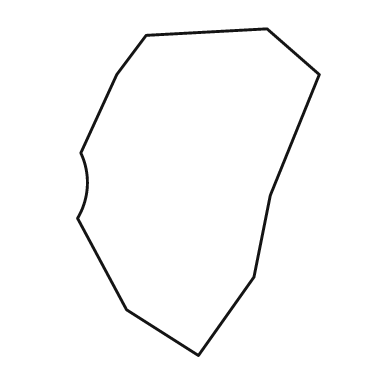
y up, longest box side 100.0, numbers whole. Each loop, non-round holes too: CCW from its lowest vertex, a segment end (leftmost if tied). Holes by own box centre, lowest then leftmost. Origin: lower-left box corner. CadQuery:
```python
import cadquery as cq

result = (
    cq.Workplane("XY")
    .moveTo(37.0, 0.0)
    .lineTo(54.0, 24.0)
    .lineTo(59.0, 49.0)
    .lineTo(74.0, 86.0)
    .lineTo(58.0, 100.0)
    .lineTo(21.0, 98.0)
    .lineTo(12.0, 86.0)
    .lineTo(1.0, 62.0)
    .threePointArc((3.0, 52.0), (0.0, 42.0))
    .lineTo(15.0, 14.0)
    .close()
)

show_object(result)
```